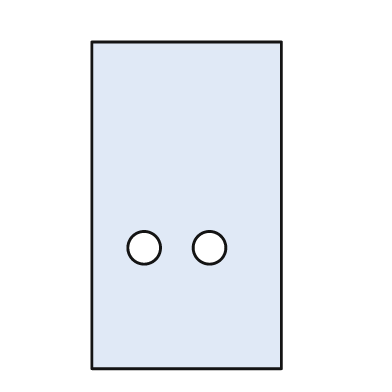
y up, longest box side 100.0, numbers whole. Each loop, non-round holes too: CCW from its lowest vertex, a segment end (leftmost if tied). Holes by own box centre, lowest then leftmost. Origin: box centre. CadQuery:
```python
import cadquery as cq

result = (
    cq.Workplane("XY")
    .moveTo(-29.0, -50.0)
    .lineTo(29.0, -50.0)
    .lineTo(29.0, 50.0)
    .lineTo(-29.0, 50.0)
    .close()
    .moveTo(-13.0, -13.0)
    .circle(5.0)
    .moveTo(7.0, -13.0)
    .circle(5.0)
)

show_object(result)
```